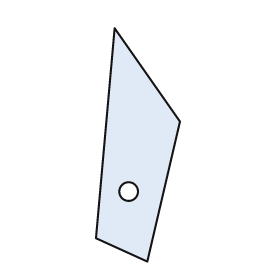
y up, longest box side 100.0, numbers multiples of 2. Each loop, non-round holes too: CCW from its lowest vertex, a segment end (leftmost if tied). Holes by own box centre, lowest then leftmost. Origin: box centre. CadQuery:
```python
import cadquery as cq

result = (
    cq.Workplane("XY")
    .moveTo(4.0, -50.0)
    .lineTo(18.0, 10.0)
    .lineTo(-10.0, 50.0)
    .lineTo(-18.0, -40.0)
    .close()
    .moveTo(-4.0, -20.0)
    .circle(4.0)
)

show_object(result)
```